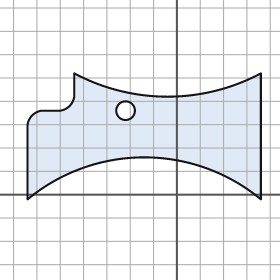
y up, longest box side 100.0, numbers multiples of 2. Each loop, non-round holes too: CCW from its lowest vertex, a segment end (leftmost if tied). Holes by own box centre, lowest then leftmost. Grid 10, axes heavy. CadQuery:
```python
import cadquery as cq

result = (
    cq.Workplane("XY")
    .moveTo(-64.0, -2.0)
    .threePointArc((-14.0, 16.0), (36.0, -2.0))
    .lineTo(36.0, 52.0)
    .threePointArc((-4.0, 42.0), (-44.0, 52.0))
    .lineTo(-44.0, 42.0)
    .threePointArc((-46.0, 38.0), (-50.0, 36.0))
    .lineTo(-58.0, 36.0)
    .threePointArc((-62.0, 34.0), (-64.0, 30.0))
    .close()
    .moveTo(-22.0, 36.0)
    .circle(4.0)
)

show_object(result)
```